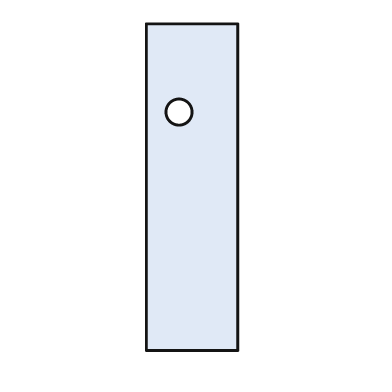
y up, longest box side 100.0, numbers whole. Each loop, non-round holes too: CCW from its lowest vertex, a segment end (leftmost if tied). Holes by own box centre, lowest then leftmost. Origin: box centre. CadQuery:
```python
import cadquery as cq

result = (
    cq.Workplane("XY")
    .moveTo(-14.0, -50.0)
    .lineTo(14.0, -50.0)
    .lineTo(14.0, 50.0)
    .lineTo(-14.0, 50.0)
    .close()
    .moveTo(-4.0, 23.0)
    .circle(4.0)
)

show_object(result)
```